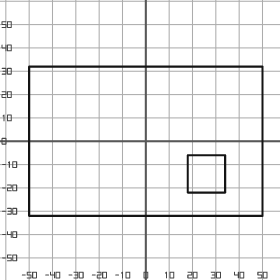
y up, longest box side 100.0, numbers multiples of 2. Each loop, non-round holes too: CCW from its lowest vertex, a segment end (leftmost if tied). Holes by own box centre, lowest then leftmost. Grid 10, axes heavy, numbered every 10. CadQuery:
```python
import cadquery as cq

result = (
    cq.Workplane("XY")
    .moveTo(-50.0, -32.0)
    .lineTo(50.0, -32.0)
    .lineTo(50.0, 32.0)
    .lineTo(-50.0, 32.0)
    .close()
    .moveTo(18.0, -22.0)
    .lineTo(34.0, -22.0)
    .lineTo(34.0, -6.0)
    .lineTo(18.0, -6.0)
    .close()
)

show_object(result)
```